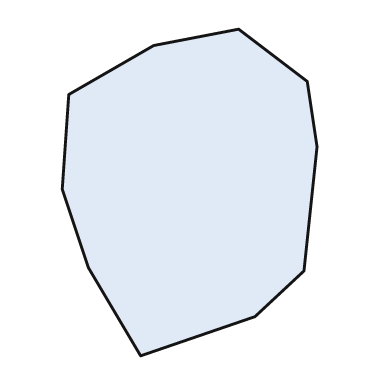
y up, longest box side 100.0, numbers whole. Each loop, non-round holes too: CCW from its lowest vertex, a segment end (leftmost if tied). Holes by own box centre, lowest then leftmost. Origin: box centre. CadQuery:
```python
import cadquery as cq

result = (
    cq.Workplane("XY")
    .moveTo(-15.0, -50.0)
    .lineTo(20.0, -38.0)
    .lineTo(35.0, -24.0)
    .lineTo(39.0, 14.0)
    .lineTo(36.0, 34.0)
    .lineTo(15.0, 50.0)
    .lineTo(-11.0, 45.0)
    .lineTo(-37.0, 30.0)
    .lineTo(-39.0, 1.0)
    .lineTo(-31.0, -23.0)
    .close()
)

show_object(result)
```